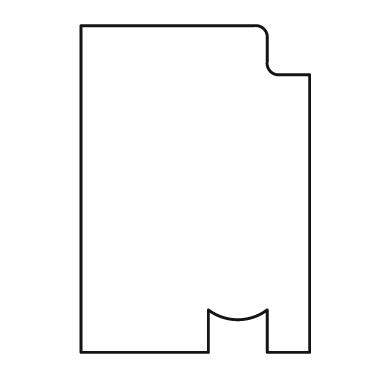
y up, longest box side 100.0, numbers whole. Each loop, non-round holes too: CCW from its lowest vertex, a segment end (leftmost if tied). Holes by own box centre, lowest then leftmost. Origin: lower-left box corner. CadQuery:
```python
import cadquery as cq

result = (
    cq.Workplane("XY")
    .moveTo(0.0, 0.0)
    .lineTo(39.0, 0.0)
    .lineTo(39.0, 13.0)
    .threePointArc((48.0, 10.0), (57.0, 13.0))
    .lineTo(57.0, 0.0)
    .lineTo(70.0, 0.0)
    .lineTo(70.0, 85.0)
    .lineTo(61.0, 85.0)
    .threePointArc((58.0, 86.0), (57.0, 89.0))
    .lineTo(57.0, 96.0)
    .threePointArc((56.0, 99.0), (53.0, 100.0))
    .lineTo(0.0, 100.0)
    .close()
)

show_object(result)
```